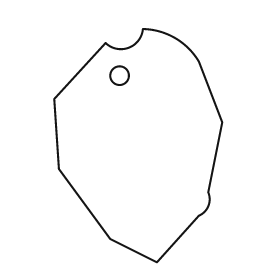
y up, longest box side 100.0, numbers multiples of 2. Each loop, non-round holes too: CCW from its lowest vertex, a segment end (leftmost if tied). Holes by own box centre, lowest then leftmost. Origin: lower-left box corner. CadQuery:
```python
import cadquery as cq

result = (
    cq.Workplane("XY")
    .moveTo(44.0, 0.0)
    .lineTo(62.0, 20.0)
    .threePointArc((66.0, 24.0), (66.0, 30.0))
    .lineTo(72.0, 60.0)
    .lineTo(62.0, 86.0)
    .threePointArc((52.0, 96.0), (38.0, 100.0))
    .threePointArc((32.0, 92.0), (22.0, 94.0))
    .lineTo(0.0, 70.0)
    .lineTo(2.0, 40.0)
    .lineTo(24.0, 10.0)
    .close()
    .moveTo(28.0, 80.0)
    .circle(4.0)
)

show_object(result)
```